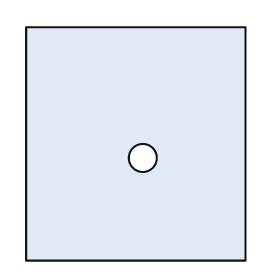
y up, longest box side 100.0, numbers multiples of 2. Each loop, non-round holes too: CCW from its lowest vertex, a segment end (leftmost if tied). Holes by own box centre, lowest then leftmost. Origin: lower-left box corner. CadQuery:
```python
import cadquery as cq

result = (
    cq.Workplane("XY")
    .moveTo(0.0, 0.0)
    .lineTo(94.0, 0.0)
    .lineTo(94.0, 100.0)
    .lineTo(0.0, 100.0)
    .close()
    .moveTo(50.0, 44.0)
    .circle(6.0)
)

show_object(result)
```